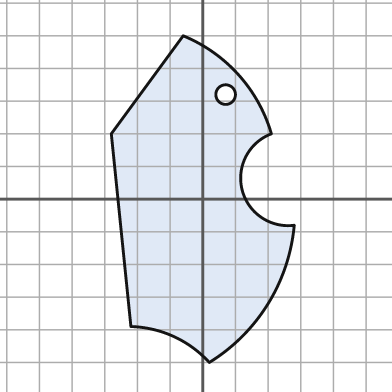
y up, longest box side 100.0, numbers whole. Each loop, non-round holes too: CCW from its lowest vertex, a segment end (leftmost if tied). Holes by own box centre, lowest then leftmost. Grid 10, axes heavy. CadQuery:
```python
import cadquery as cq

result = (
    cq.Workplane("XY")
    .moveTo(2.0, -50.0)
    .threePointArc((20.0, -32.0), (28.0, -8.0))
    .threePointArc((12.0, 3.0), (21.0, 20.0))
    .threePointArc((11.0, 38.0), (-6.0, 50.0))
    .lineTo(-28.0, 20.0)
    .lineTo(-22.0, -39.0)
    .threePointArc((-9.0, -42.0), (2.0, -50.0))
    .close()
    .moveTo(7.0, 32.0)
    .circle(3.0)
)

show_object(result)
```